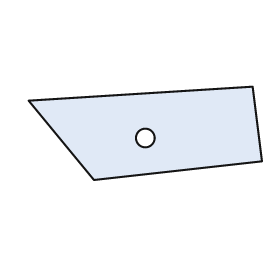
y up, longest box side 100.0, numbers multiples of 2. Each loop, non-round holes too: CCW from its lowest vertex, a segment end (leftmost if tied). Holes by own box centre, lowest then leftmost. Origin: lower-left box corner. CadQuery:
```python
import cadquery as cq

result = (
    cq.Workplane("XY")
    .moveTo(28.0, 0.0)
    .lineTo(100.0, 8.0)
    .lineTo(96.0, 40.0)
    .lineTo(0.0, 34.0)
    .close()
    .moveTo(50.0, 18.0)
    .circle(4.0)
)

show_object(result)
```